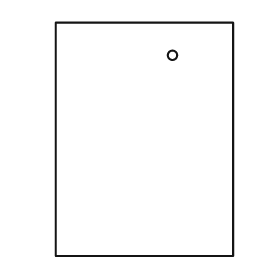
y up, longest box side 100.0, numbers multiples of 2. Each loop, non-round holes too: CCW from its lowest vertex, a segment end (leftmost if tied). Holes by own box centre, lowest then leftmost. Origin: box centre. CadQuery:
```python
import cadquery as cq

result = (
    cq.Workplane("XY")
    .moveTo(-38.0, -50.0)
    .lineTo(38.0, -50.0)
    .lineTo(38.0, 50.0)
    .lineTo(-38.0, 50.0)
    .close()
    .moveTo(12.0, 36.0)
    .circle(2.0)
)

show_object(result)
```